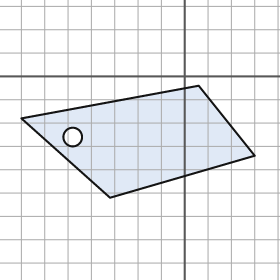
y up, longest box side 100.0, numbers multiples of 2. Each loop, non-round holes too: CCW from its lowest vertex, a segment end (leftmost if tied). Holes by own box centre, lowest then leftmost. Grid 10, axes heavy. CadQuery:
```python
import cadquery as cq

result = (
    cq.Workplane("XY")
    .moveTo(-32.0, -52.0)
    .lineTo(30.0, -34.0)
    .lineTo(6.0, -4.0)
    .lineTo(-70.0, -18.0)
    .close()
    .moveTo(-48.0, -26.0)
    .circle(4.0)
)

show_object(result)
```